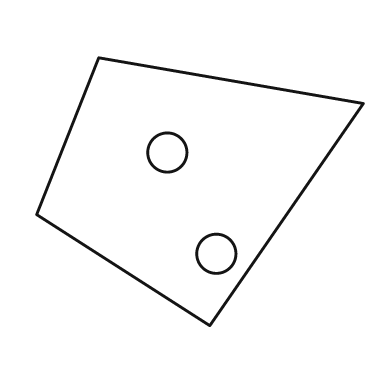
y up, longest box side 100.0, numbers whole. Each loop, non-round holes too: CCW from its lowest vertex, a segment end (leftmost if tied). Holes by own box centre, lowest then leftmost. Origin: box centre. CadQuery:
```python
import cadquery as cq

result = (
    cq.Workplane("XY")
    .moveTo(3.0, -41.0)
    .lineTo(50.0, 27.0)
    .lineTo(-31.0, 41.0)
    .lineTo(-50.0, -7.0)
    .close()
    .moveTo(5.0, -19.0)
    .circle(6.0)
    .moveTo(-10.0, 12.0)
    .circle(6.0)
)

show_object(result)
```